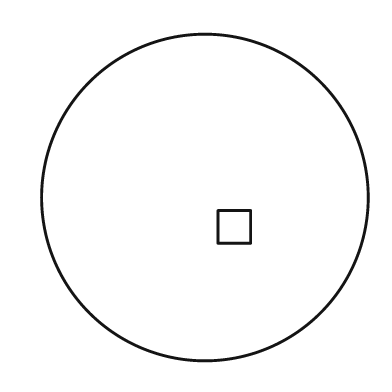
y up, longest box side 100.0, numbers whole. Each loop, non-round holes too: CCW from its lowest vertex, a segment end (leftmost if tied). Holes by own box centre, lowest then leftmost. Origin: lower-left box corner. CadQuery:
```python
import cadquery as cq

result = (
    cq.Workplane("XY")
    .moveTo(50.0, 50.0)
    .circle(50.0)
    .moveTo(54.0, 36.0)
    .lineTo(64.0, 36.0)
    .lineTo(64.0, 46.0)
    .lineTo(54.0, 46.0)
    .close()
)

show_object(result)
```